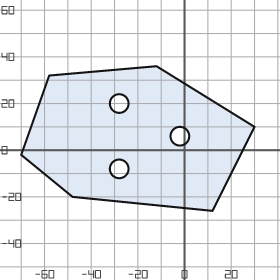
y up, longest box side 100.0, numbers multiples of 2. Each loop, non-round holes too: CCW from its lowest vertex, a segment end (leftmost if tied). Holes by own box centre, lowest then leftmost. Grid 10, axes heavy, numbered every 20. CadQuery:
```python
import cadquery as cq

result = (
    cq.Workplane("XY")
    .moveTo(12.0, -26.0)
    .lineTo(30.0, 10.0)
    .lineTo(-12.0, 36.0)
    .lineTo(-58.0, 32.0)
    .lineTo(-70.0, -2.0)
    .lineTo(-48.0, -20.0)
    .close()
    .moveTo(-28.0, -8.0)
    .circle(4.0)
    .moveTo(-2.0, 6.0)
    .circle(4.0)
    .moveTo(-28.0, 20.0)
    .circle(4.0)
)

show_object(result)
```